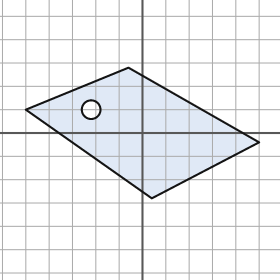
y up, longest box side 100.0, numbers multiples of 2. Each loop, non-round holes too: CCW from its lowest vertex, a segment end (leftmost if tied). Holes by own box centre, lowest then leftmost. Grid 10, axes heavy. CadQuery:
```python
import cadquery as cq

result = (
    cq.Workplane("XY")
    .moveTo(4.0, -28.0)
    .lineTo(50.0, -4.0)
    .lineTo(-6.0, 28.0)
    .lineTo(-50.0, 10.0)
    .close()
    .moveTo(-22.0, 10.0)
    .circle(4.0)
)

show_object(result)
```